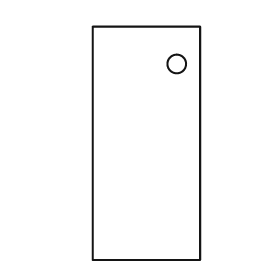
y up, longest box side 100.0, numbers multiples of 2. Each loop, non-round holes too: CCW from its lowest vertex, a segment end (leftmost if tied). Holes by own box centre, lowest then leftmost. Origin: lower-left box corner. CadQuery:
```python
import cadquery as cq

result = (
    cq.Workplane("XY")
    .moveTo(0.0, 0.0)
    .lineTo(46.0, 0.0)
    .lineTo(46.0, 100.0)
    .lineTo(0.0, 100.0)
    .close()
    .moveTo(36.0, 84.0)
    .circle(4.0)
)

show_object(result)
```